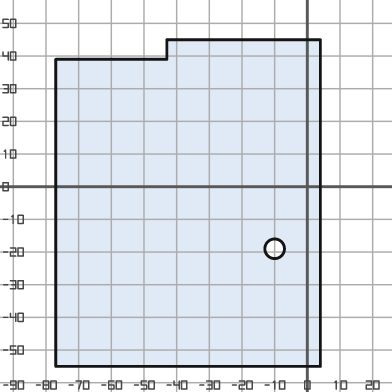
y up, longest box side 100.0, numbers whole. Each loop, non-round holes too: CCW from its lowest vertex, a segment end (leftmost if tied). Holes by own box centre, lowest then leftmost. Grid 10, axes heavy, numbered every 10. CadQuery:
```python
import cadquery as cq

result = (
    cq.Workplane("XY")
    .moveTo(-77.0, -55.0)
    .lineTo(4.0, -55.0)
    .lineTo(4.0, 45.0)
    .lineTo(-43.0, 45.0)
    .lineTo(-43.0, 39.0)
    .lineTo(-77.0, 39.0)
    .close()
    .moveTo(-10.0, -19.0)
    .circle(3.0)
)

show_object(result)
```